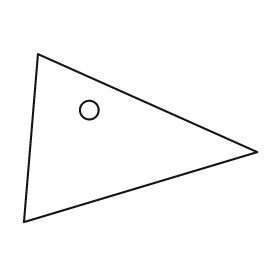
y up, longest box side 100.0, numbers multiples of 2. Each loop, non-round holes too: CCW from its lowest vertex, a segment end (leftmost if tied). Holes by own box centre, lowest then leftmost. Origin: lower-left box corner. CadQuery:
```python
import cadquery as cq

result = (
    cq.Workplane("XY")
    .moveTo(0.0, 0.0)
    .lineTo(100.0, 30.0)
    .lineTo(6.0, 72.0)
    .close()
    .moveTo(28.0, 48.0)
    .circle(4.0)
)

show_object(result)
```